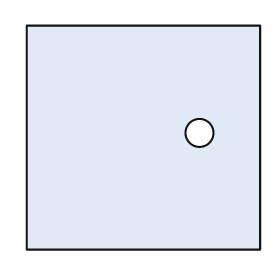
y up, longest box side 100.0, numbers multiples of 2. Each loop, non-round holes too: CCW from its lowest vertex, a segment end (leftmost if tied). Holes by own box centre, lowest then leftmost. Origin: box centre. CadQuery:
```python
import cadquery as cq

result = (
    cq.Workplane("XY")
    .moveTo(-50.0, -48.0)
    .lineTo(50.0, -48.0)
    .lineTo(50.0, 48.0)
    .lineTo(-50.0, 48.0)
    .close()
    .moveTo(24.0, 2.0)
    .circle(6.0)
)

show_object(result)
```